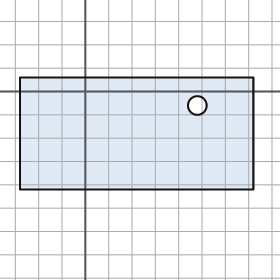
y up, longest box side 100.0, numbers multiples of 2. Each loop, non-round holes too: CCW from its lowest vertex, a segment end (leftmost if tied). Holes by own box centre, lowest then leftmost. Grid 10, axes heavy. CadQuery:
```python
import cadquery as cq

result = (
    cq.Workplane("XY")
    .moveTo(-28.0, -42.0)
    .lineTo(72.0, -42.0)
    .lineTo(72.0, 6.0)
    .lineTo(-28.0, 6.0)
    .close()
    .moveTo(48.0, -6.0)
    .circle(4.0)
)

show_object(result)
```